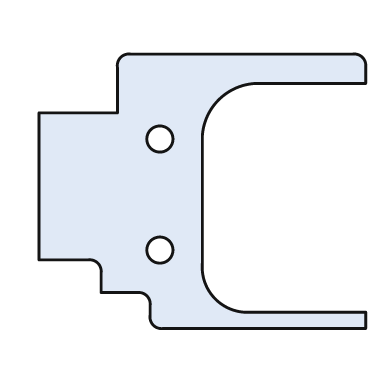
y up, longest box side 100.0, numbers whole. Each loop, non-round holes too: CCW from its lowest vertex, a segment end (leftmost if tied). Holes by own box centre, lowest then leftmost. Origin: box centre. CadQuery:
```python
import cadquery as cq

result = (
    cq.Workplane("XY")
    .moveTo(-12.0, -42.0)
    .lineTo(50.0, -42.0)
    .lineTo(50.0, -37.0)
    .lineTo(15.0, -37.0)
    .threePointArc((4.0, -33.0), (0.0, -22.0))
    .lineTo(0.0, 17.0)
    .threePointArc((5.0, 28.0), (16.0, 33.0))
    .lineTo(50.0, 33.0)
    .lineTo(50.0, 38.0)
    .threePointArc((49.0, 41.0), (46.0, 42.0))
    .lineTo(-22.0, 42.0)
    .threePointArc((-25.0, 41.0), (-26.0, 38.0))
    .lineTo(-26.0, 24.0)
    .lineTo(-50.0, 24.0)
    .lineTo(-50.0, -21.0)
    .lineTo(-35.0, -21.0)
    .threePointArc((-32.0, -22.0), (-31.0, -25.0))
    .lineTo(-31.0, -31.0)
    .lineTo(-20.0, -31.0)
    .threePointArc((-17.0, -32.0), (-16.0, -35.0))
    .lineTo(-16.0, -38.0)
    .threePointArc((-15.0, -41.0), (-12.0, -42.0))
    .close()
    .moveTo(-13.0, -18.0)
    .circle(4.0)
    .moveTo(-13.0, 16.0)
    .circle(4.0)
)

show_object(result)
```